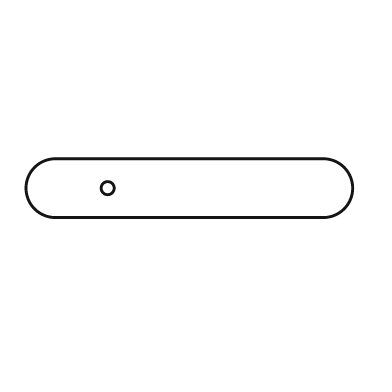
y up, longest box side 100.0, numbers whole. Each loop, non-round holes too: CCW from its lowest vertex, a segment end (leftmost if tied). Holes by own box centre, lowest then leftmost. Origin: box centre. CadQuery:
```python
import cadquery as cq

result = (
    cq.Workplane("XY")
    .moveTo(-41.0, -9.0)
    .lineTo(41.0, -9.0)
    .threePointArc((50.0, 0.0), (41.0, 9.0))
    .lineTo(-41.0, 9.0)
    .threePointArc((-50.0, 0.0), (-41.0, -9.0))
    .close()
    .moveTo(-25.0, 0.0)
    .circle(2.0)
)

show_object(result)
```